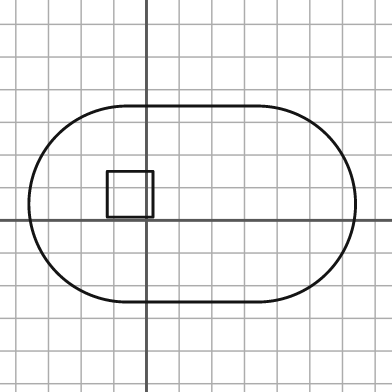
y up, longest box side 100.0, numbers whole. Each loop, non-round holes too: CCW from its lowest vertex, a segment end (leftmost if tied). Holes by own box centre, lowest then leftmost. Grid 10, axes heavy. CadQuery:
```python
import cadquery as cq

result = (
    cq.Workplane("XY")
    .moveTo(-6.0, -25.0)
    .lineTo(34.0, -25.0)
    .threePointArc((64.0, 5.0), (34.0, 35.0))
    .lineTo(-6.0, 35.0)
    .threePointArc((-36.0, 5.0), (-6.0, -25.0))
    .close()
    .moveTo(-12.0, 1.0)
    .lineTo(2.0, 1.0)
    .lineTo(2.0, 15.0)
    .lineTo(-12.0, 15.0)
    .close()
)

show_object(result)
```